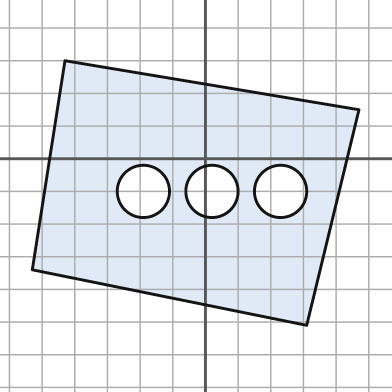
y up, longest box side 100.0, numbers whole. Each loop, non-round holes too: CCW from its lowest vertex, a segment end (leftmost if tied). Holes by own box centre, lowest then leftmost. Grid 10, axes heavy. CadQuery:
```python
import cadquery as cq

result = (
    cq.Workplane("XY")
    .moveTo(31.0, -51.0)
    .lineTo(47.0, 15.0)
    .lineTo(-43.0, 30.0)
    .lineTo(-53.0, -34.0)
    .close()
    .moveTo(-19.0, -10.0)
    .circle(8.0)
    .moveTo(2.0, -10.0)
    .circle(8.0)
    .moveTo(23.0, -10.0)
    .circle(8.0)
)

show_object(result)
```